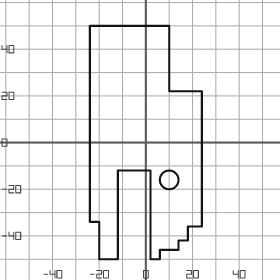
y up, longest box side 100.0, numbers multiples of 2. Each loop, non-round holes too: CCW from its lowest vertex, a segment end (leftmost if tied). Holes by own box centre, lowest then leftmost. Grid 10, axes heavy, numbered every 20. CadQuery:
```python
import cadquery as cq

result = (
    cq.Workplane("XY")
    .moveTo(-20.0, -50.0)
    .lineTo(-12.0, -50.0)
    .lineTo(-12.0, -12.0)
    .lineTo(2.0, -12.0)
    .lineTo(2.0, -50.0)
    .lineTo(6.0, -50.0)
    .lineTo(6.0, -46.0)
    .lineTo(14.0, -46.0)
    .lineTo(14.0, -42.0)
    .lineTo(18.0, -42.0)
    .lineTo(18.0, -36.0)
    .lineTo(24.0, -36.0)
    .lineTo(24.0, 22.0)
    .lineTo(10.0, 22.0)
    .lineTo(10.0, 50.0)
    .lineTo(-24.0, 50.0)
    .lineTo(-24.0, -34.0)
    .lineTo(-20.0, -34.0)
    .close()
    .moveTo(10.0, -16.0)
    .circle(4.0)
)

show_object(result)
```